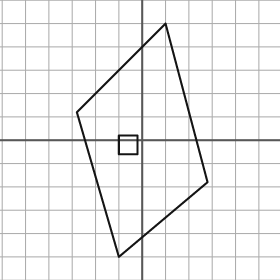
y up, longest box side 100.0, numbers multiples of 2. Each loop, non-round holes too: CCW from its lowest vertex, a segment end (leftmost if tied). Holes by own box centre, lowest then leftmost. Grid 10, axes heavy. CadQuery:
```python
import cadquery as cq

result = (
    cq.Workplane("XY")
    .moveTo(-10.0, -50.0)
    .lineTo(28.0, -18.0)
    .lineTo(10.0, 50.0)
    .lineTo(-28.0, 12.0)
    .close()
    .moveTo(-10.0, -6.0)
    .lineTo(-2.0, -6.0)
    .lineTo(-2.0, 2.0)
    .lineTo(-10.0, 2.0)
    .close()
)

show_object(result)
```